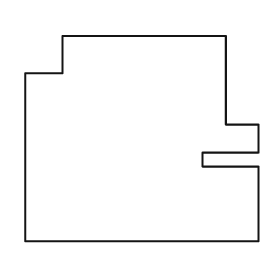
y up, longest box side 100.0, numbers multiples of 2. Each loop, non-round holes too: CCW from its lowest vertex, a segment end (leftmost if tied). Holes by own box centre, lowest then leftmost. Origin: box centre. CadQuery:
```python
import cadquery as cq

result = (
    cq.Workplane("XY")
    .moveTo(-50.0, -44.0)
    .lineTo(50.0, -44.0)
    .lineTo(50.0, -12.0)
    .lineTo(26.0, -12.0)
    .lineTo(26.0, -6.0)
    .lineTo(50.0, -6.0)
    .lineTo(50.0, 6.0)
    .lineTo(36.0, 6.0)
    .lineTo(36.0, 44.0)
    .lineTo(-34.0, 44.0)
    .lineTo(-34.0, 28.0)
    .lineTo(-50.0, 28.0)
    .close()
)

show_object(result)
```